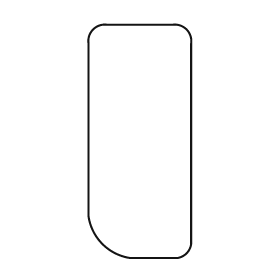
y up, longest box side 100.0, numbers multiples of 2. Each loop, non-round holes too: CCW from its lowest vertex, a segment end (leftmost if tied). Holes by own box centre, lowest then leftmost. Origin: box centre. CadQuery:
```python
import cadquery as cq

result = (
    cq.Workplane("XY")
    .moveTo(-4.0, -50.0)
    .lineTo(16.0, -50.0)
    .threePointArc((20.0, -48.0), (22.0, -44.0))
    .lineTo(22.0, 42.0)
    .threePointArc((20.0, 48.0), (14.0, 50.0))
    .lineTo(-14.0, 50.0)
    .threePointArc((-20.0, 48.0), (-22.0, 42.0))
    .lineTo(-22.0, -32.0)
    .threePointArc((-16.0, -44.0), (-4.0, -50.0))
    .close()
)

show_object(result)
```